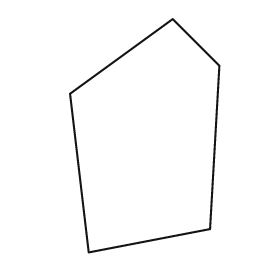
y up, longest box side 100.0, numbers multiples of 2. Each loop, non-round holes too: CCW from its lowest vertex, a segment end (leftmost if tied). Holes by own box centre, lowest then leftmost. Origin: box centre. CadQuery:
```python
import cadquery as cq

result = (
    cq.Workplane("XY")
    .moveTo(-24.0, -50.0)
    .lineTo(28.0, -40.0)
    .lineTo(32.0, 30.0)
    .lineTo(12.0, 50.0)
    .lineTo(-32.0, 18.0)
    .close()
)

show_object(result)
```